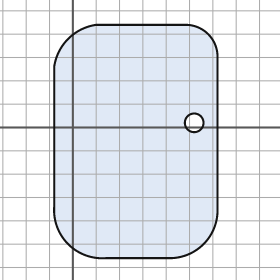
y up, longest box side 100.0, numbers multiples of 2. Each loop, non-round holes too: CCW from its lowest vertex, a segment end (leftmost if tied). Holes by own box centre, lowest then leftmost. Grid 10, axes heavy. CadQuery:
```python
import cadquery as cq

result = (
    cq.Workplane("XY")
    .moveTo(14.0, -56.0)
    .lineTo(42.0, -56.0)
    .threePointArc((56.0, -50.0), (62.0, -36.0))
    .lineTo(62.0, 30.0)
    .threePointArc((58.0, 40.0), (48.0, 44.0))
    .lineTo(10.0, 44.0)
    .threePointArc((-2.0, 38.0), (-8.0, 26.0))
    .lineTo(-8.0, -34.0)
    .threePointArc((-2.0, -50.0), (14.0, -56.0))
    .close()
    .moveTo(52.0, 2.0)
    .circle(4.0)
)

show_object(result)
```